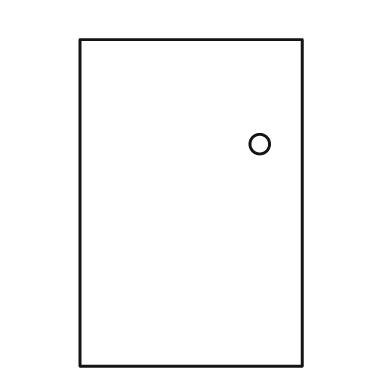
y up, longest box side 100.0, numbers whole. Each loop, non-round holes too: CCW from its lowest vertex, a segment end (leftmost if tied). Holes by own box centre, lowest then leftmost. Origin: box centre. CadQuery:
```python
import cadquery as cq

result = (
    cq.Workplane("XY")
    .moveTo(-34.0, -50.0)
    .lineTo(34.0, -50.0)
    .lineTo(34.0, 50.0)
    .lineTo(-34.0, 50.0)
    .close()
    .moveTo(21.0, 18.0)
    .circle(3.0)
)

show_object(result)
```